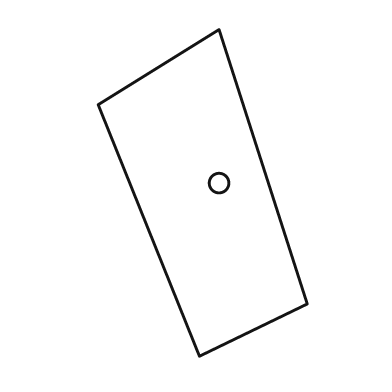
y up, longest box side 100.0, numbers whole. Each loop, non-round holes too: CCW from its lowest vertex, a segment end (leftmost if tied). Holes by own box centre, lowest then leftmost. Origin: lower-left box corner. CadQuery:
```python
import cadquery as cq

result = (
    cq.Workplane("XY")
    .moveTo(31.0, 0.0)
    .lineTo(64.0, 16.0)
    .lineTo(37.0, 100.0)
    .lineTo(0.0, 77.0)
    .close()
    .moveTo(37.0, 53.0)
    .circle(3.0)
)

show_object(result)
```